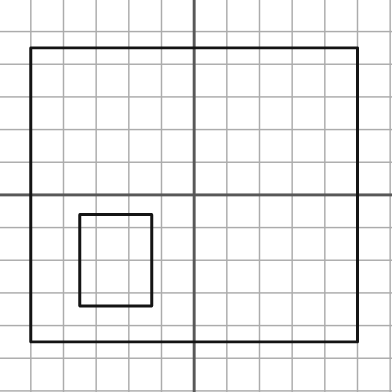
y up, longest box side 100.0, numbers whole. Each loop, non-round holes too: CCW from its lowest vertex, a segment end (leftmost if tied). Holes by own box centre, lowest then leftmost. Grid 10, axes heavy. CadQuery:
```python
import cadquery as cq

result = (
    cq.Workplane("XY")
    .moveTo(-50.0, -45.0)
    .lineTo(50.0, -45.0)
    .lineTo(50.0, 45.0)
    .lineTo(-50.0, 45.0)
    .close()
    .moveTo(-35.0, -34.0)
    .lineTo(-13.0, -34.0)
    .lineTo(-13.0, -6.0)
    .lineTo(-35.0, -6.0)
    .close()
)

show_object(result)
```